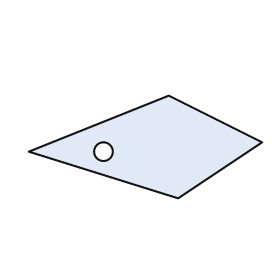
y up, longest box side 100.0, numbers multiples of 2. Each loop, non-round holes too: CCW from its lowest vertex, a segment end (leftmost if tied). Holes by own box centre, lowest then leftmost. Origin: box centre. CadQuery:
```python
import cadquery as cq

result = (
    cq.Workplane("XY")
    .moveTo(14.0, -22.0)
    .lineTo(50.0, 2.0)
    .lineTo(10.0, 22.0)
    .lineTo(-50.0, -2.0)
    .close()
    .moveTo(-18.0, -2.0)
    .circle(4.0)
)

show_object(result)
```